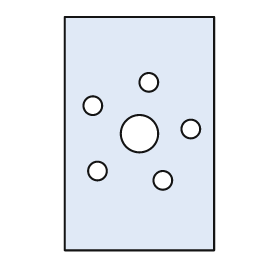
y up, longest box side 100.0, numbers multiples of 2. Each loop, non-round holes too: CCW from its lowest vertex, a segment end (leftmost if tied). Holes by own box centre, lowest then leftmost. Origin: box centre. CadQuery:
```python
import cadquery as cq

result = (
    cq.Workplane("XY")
    .moveTo(-32.0, -50.0)
    .lineTo(32.0, -50.0)
    .lineTo(32.0, 50.0)
    .lineTo(-32.0, 50.0)
    .close()
    .moveTo(10.0, -20.0)
    .circle(4.0)
    .moveTo(-18.0, -16.0)
    .circle(4.0)
    .moveTo(0.0, 0.0)
    .circle(8.0)
    .moveTo(22.0, 2.0)
    .circle(4.0)
    .moveTo(-20.0, 12.0)
    .circle(4.0)
    .moveTo(4.0, 22.0)
    .circle(4.0)
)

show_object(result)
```